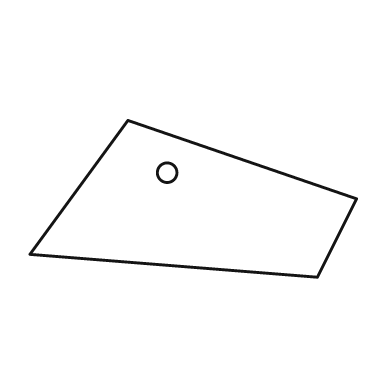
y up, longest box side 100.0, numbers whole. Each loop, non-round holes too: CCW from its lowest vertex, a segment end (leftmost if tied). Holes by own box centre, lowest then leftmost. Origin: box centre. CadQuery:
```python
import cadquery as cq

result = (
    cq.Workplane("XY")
    .moveTo(38.0, -24.0)
    .lineTo(50.0, 0.0)
    .lineTo(-20.0, 24.0)
    .lineTo(-50.0, -17.0)
    .close()
    .moveTo(-8.0, 8.0)
    .circle(3.0)
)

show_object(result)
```